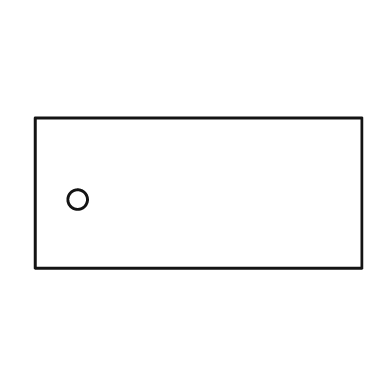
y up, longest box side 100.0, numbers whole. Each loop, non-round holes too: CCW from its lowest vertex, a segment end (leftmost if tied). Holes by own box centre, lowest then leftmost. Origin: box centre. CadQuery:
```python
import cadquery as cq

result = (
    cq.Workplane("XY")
    .moveTo(-50.0, -23.0)
    .lineTo(50.0, -23.0)
    .lineTo(50.0, 23.0)
    .lineTo(-50.0, 23.0)
    .close()
    .moveTo(-37.0, -2.0)
    .circle(3.0)
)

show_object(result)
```